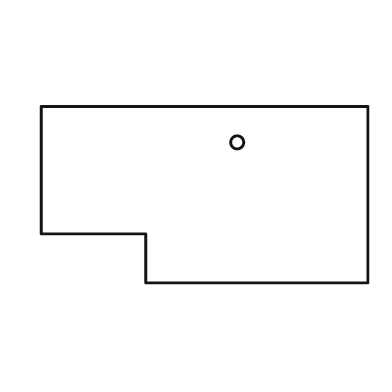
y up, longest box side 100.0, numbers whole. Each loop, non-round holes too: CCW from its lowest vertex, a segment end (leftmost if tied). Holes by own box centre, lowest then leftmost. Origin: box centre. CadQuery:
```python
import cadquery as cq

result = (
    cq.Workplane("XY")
    .moveTo(-18.0, -27.0)
    .lineTo(50.0, -27.0)
    .lineTo(50.0, 27.0)
    .lineTo(-50.0, 27.0)
    .lineTo(-50.0, -12.0)
    .lineTo(-18.0, -12.0)
    .close()
    .moveTo(10.0, 16.0)
    .circle(2.0)
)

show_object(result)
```